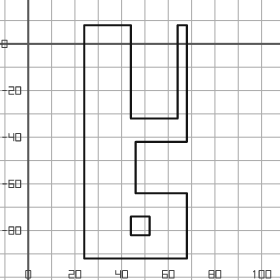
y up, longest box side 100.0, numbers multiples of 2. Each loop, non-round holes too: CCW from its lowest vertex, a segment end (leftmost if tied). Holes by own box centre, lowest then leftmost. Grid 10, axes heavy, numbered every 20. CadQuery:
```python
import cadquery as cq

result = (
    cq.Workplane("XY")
    .moveTo(24.0, -92.0)
    .lineTo(68.0, -92.0)
    .lineTo(68.0, -64.0)
    .lineTo(46.0, -64.0)
    .lineTo(46.0, -42.0)
    .lineTo(68.0, -42.0)
    .lineTo(68.0, 8.0)
    .lineTo(64.0, 8.0)
    .lineTo(64.0, -32.0)
    .lineTo(44.0, -32.0)
    .lineTo(44.0, 8.0)
    .lineTo(24.0, 8.0)
    .close()
    .moveTo(44.0, -82.0)
    .lineTo(52.0, -82.0)
    .lineTo(52.0, -74.0)
    .lineTo(44.0, -74.0)
    .close()
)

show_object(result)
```